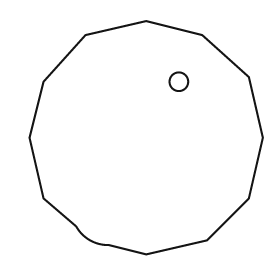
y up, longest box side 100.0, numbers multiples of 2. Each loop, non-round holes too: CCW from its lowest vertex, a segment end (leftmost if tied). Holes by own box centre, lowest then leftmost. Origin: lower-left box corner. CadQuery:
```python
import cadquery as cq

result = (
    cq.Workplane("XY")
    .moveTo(50.0, 0.0)
    .lineTo(76.0, 6.0)
    .lineTo(94.0, 24.0)
    .lineTo(100.0, 50.0)
    .lineTo(94.0, 76.0)
    .lineTo(74.0, 94.0)
    .lineTo(50.0, 100.0)
    .lineTo(24.0, 94.0)
    .lineTo(6.0, 74.0)
    .lineTo(0.0, 50.0)
    .lineTo(6.0, 24.0)
    .lineTo(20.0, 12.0)
    .threePointArc((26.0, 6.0), (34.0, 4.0))
    .close()
    .moveTo(64.0, 74.0)
    .circle(4.0)
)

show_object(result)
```